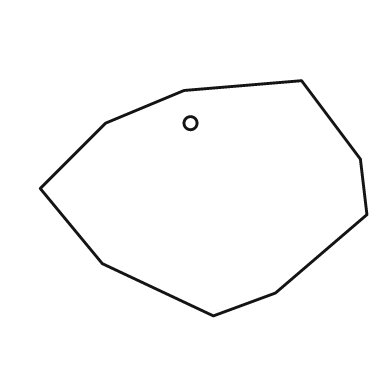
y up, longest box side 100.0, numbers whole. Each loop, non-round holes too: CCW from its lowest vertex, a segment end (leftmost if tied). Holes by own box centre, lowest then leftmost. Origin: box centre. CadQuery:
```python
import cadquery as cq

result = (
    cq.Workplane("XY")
    .moveTo(3.0, -36.0)
    .lineTo(22.0, -29.0)
    .lineTo(50.0, -5.0)
    .lineTo(48.0, 12.0)
    .lineTo(30.0, 36.0)
    .lineTo(-6.0, 33.0)
    .lineTo(-30.0, 23.0)
    .lineTo(-50.0, 3.0)
    .lineTo(-31.0, -20.0)
    .close()
    .moveTo(-4.0, 23.0)
    .circle(2.0)
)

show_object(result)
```